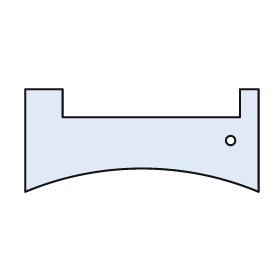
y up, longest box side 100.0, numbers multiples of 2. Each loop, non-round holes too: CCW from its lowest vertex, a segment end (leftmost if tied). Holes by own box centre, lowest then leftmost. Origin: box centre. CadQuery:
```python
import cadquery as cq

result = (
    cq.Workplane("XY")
    .moveTo(-50.0, -22.0)
    .threePointArc((0.0, -12.0), (50.0, -22.0))
    .lineTo(50.0, 22.0)
    .lineTo(42.0, 22.0)
    .lineTo(42.0, 10.0)
    .lineTo(-34.0, 10.0)
    .lineTo(-34.0, 22.0)
    .lineTo(-50.0, 22.0)
    .close()
    .moveTo(38.0, 0.0)
    .circle(2.0)
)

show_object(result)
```